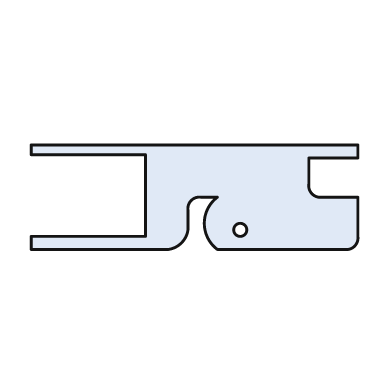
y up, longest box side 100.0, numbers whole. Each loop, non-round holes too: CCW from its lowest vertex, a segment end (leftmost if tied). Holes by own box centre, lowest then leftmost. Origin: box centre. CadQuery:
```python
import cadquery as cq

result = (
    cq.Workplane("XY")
    .moveTo(-50.0, -16.0)
    .lineTo(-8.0, -16.0)
    .threePointArc((-4.0, -14.0), (-2.0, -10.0))
    .lineTo(-2.0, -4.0)
    .threePointArc((-1.0, -1.0), (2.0, 0.0))
    .lineTo(7.0, 0.0)
    .threePointArc((3.0, -8.0), (7.0, -16.0))
    .lineTo(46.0, -16.0)
    .threePointArc((49.0, -15.0), (50.0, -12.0))
    .lineTo(50.0, 0.0)
    .lineTo(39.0, 0.0)
    .threePointArc((36.0, 1.0), (35.0, 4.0))
    .lineTo(35.0, 12.0)
    .lineTo(50.0, 12.0)
    .lineTo(50.0, 16.0)
    .lineTo(-50.0, 16.0)
    .lineTo(-50.0, 13.0)
    .lineTo(-15.0, 13.0)
    .lineTo(-15.0, -12.0)
    .lineTo(-50.0, -12.0)
    .close()
    .moveTo(14.0, -10.0)
    .circle(2.0)
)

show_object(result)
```